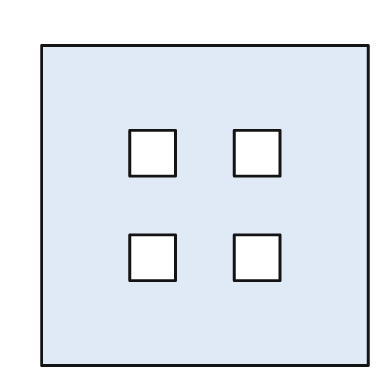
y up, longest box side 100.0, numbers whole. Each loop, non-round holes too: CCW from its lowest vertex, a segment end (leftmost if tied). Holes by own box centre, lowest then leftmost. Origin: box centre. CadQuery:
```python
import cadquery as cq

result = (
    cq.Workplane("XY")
    .moveTo(-50.0, -49.0)
    .lineTo(50.0, -49.0)
    .lineTo(50.0, 49.0)
    .lineTo(-50.0, 49.0)
    .close()
    .moveTo(-23.0, -23.0)
    .lineTo(-9.0, -23.0)
    .lineTo(-9.0, -9.0)
    .lineTo(-23.0, -9.0)
    .close()
    .moveTo(9.0, -23.0)
    .lineTo(23.0, -23.0)
    .lineTo(23.0, -9.0)
    .lineTo(9.0, -9.0)
    .close()
    .moveTo(-23.0, 9.0)
    .lineTo(-9.0, 9.0)
    .lineTo(-9.0, 23.0)
    .lineTo(-23.0, 23.0)
    .close()
    .moveTo(9.0, 9.0)
    .lineTo(23.0, 9.0)
    .lineTo(23.0, 23.0)
    .lineTo(9.0, 23.0)
    .close()
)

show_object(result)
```